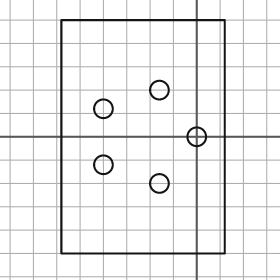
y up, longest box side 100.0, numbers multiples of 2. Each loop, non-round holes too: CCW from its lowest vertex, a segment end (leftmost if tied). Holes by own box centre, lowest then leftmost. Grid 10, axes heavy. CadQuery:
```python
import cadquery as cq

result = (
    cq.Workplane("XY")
    .moveTo(-58.0, -50.0)
    .lineTo(12.0, -50.0)
    .lineTo(12.0, 50.0)
    .lineTo(-58.0, 50.0)
    .close()
    .moveTo(-16.0, -20.0)
    .circle(4.0)
    .moveTo(-40.0, -12.0)
    .circle(4.0)
    .moveTo(0.0, 0.0)
    .circle(4.0)
    .moveTo(-40.0, 12.0)
    .circle(4.0)
    .moveTo(-16.0, 20.0)
    .circle(4.0)
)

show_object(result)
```